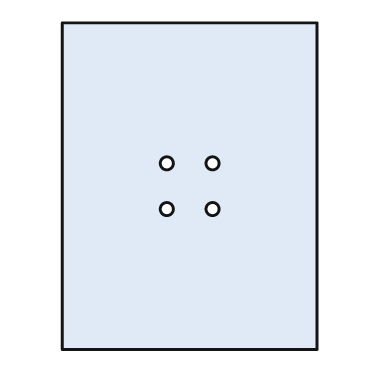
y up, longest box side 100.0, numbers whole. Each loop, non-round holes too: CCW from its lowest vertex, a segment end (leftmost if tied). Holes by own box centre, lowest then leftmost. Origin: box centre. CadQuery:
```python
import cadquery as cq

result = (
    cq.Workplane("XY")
    .moveTo(-39.0, -50.0)
    .lineTo(39.0, -50.0)
    .lineTo(39.0, 50.0)
    .lineTo(-39.0, 50.0)
    .close()
    .moveTo(-7.0, -7.0)
    .circle(2.0)
    .moveTo(7.0, -7.0)
    .circle(2.0)
    .moveTo(-7.0, 7.0)
    .circle(2.0)
    .moveTo(7.0, 7.0)
    .circle(2.0)
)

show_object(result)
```